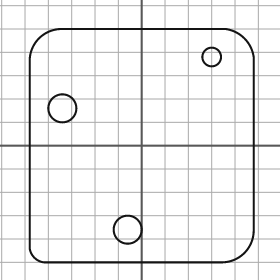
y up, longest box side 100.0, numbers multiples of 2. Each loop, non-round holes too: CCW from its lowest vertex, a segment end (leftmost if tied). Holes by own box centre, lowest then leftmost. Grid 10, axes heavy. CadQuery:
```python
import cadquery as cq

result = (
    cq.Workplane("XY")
    .moveTo(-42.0, -50.0)
    .lineTo(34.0, -50.0)
    .threePointArc((44.0, -46.0), (48.0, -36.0))
    .lineTo(48.0, 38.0)
    .threePointArc((44.0, 46.0), (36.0, 50.0))
    .lineTo(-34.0, 50.0)
    .threePointArc((-44.0, 46.0), (-48.0, 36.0))
    .lineTo(-48.0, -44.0)
    .threePointArc((-46.0, -48.0), (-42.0, -50.0))
    .close()
    .moveTo(-6.0, -36.0)
    .circle(6.0)
    .moveTo(-34.0, 16.0)
    .circle(6.0)
    .moveTo(30.0, 38.0)
    .circle(4.0)
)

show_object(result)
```